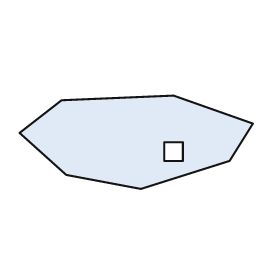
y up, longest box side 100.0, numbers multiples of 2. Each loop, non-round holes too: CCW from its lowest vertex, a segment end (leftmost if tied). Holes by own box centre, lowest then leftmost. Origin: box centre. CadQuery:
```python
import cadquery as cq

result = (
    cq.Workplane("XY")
    .moveTo(2.0, -20.0)
    .lineTo(40.0, -8.0)
    .lineTo(50.0, 8.0)
    .lineTo(16.0, 20.0)
    .lineTo(-32.0, 18.0)
    .lineTo(-50.0, 4.0)
    .lineTo(-30.0, -14.0)
    .close()
    .moveTo(12.0, -8.0)
    .lineTo(20.0, -8.0)
    .lineTo(20.0, 0.0)
    .lineTo(12.0, 0.0)
    .close()
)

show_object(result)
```